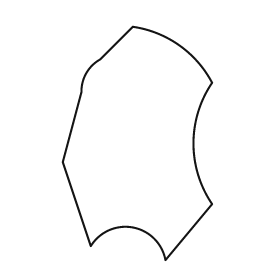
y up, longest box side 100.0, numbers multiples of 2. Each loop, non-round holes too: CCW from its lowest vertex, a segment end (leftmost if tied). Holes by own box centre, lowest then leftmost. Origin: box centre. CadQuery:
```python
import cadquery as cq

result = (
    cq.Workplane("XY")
    .moveTo(12.0, -50.0)
    .lineTo(32.0, -26.0)
    .threePointArc((24.0, 0.0), (32.0, 26.0))
    .threePointArc((18.0, 42.0), (-2.0, 50.0))
    .lineTo(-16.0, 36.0)
    .threePointArc((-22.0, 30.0), (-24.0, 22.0))
    .lineTo(-32.0, -8.0)
    .lineTo(-20.0, -44.0)
    .threePointArc((-2.0, -36.0), (12.0, -50.0))
    .close()
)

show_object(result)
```